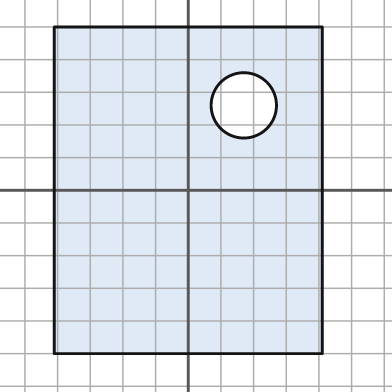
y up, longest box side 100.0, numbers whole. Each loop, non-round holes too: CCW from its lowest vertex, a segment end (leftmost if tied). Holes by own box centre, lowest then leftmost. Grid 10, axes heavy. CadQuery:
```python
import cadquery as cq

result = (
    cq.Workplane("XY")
    .moveTo(-41.0, -50.0)
    .lineTo(41.0, -50.0)
    .lineTo(41.0, 50.0)
    .lineTo(-41.0, 50.0)
    .close()
    .moveTo(17.0, 26.0)
    .circle(10.0)
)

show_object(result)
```